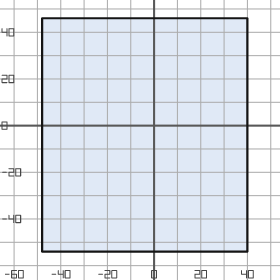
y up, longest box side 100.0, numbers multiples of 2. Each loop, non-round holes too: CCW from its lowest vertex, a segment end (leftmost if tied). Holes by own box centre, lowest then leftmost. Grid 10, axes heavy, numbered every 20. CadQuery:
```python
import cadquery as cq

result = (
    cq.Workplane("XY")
    .moveTo(-48.0, -54.0)
    .lineTo(40.0, -54.0)
    .lineTo(40.0, 46.0)
    .lineTo(-48.0, 46.0)
    .close()
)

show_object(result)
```